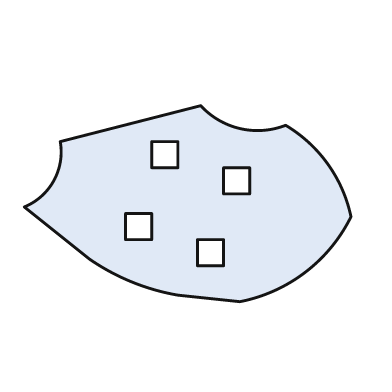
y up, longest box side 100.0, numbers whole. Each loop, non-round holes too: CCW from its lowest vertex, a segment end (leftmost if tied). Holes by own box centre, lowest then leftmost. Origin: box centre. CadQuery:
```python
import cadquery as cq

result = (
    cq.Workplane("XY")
    .moveTo(16.0, -30.0)
    .threePointArc((36.0, -21.0), (50.0, -4.0))
    .threePointArc((43.0, 12.0), (30.0, 24.0))
    .threePointArc((16.0, 23.0), (4.0, 30.0))
    .lineTo(-39.0, 19.0)
    .threePointArc((-41.0, 7.0), (-50.0, -1.0))
    .lineTo(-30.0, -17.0)
    .threePointArc((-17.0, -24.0), (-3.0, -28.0))
    .close()
    .moveTo(3.0, -19.0)
    .lineTo(11.0, -19.0)
    .lineTo(11.0, -11.0)
    .lineTo(3.0, -11.0)
    .close()
    .moveTo(-19.0, -11.0)
    .lineTo(-11.0, -11.0)
    .lineTo(-11.0, -3.0)
    .lineTo(-19.0, -3.0)
    .close()
    .moveTo(11.0, 3.0)
    .lineTo(19.0, 3.0)
    .lineTo(19.0, 11.0)
    .lineTo(11.0, 11.0)
    .close()
    .moveTo(-11.0, 11.0)
    .lineTo(-3.0, 11.0)
    .lineTo(-3.0, 19.0)
    .lineTo(-11.0, 19.0)
    .close()
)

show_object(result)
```